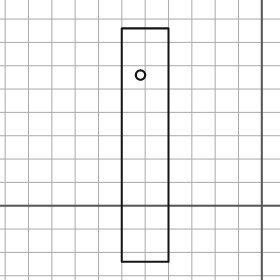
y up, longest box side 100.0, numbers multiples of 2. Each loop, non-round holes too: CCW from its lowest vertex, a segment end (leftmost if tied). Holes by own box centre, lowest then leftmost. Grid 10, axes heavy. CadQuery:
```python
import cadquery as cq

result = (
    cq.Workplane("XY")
    .moveTo(-60.0, -24.0)
    .lineTo(-40.0, -24.0)
    .lineTo(-40.0, 76.0)
    .lineTo(-60.0, 76.0)
    .close()
    .moveTo(-52.0, 56.0)
    .circle(2.0)
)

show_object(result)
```